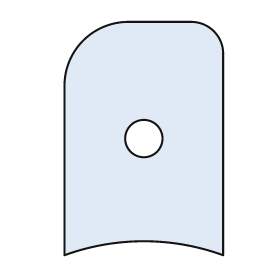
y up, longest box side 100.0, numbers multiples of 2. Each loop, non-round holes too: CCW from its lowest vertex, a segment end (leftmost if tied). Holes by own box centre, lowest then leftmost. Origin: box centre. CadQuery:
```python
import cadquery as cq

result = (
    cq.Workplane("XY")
    .moveTo(-34.0, -50.0)
    .threePointArc((0.0, -44.0), (34.0, -50.0))
    .lineTo(34.0, 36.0)
    .threePointArc((30.0, 46.0), (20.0, 50.0))
    .lineTo(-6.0, 50.0)
    .threePointArc((-26.0, 42.0), (-34.0, 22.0))
    .close()
    .moveTo(0.0, 0.0)
    .circle(8.0)
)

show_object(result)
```